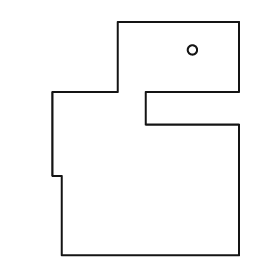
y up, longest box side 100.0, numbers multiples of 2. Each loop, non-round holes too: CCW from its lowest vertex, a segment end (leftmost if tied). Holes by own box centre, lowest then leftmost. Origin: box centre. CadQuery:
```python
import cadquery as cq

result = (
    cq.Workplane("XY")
    .moveTo(-36.0, -50.0)
    .lineTo(40.0, -50.0)
    .lineTo(40.0, 6.0)
    .lineTo(0.0, 6.0)
    .lineTo(0.0, 20.0)
    .lineTo(40.0, 20.0)
    .lineTo(40.0, 50.0)
    .lineTo(-12.0, 50.0)
    .lineTo(-12.0, 20.0)
    .lineTo(-40.0, 20.0)
    .lineTo(-40.0, -16.0)
    .lineTo(-36.0, -16.0)
    .close()
    .moveTo(20.0, 38.0)
    .circle(2.0)
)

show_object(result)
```